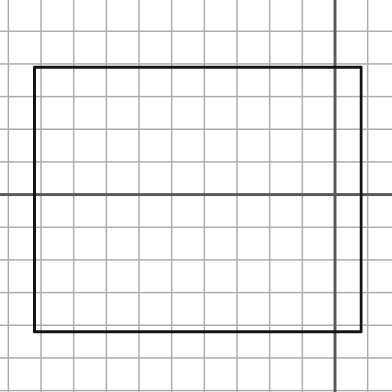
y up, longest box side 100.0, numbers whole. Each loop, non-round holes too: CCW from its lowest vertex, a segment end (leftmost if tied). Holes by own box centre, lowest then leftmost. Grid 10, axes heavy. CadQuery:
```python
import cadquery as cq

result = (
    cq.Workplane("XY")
    .moveTo(-92.0, -42.0)
    .lineTo(8.0, -42.0)
    .lineTo(8.0, 39.0)
    .lineTo(-92.0, 39.0)
    .close()
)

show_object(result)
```